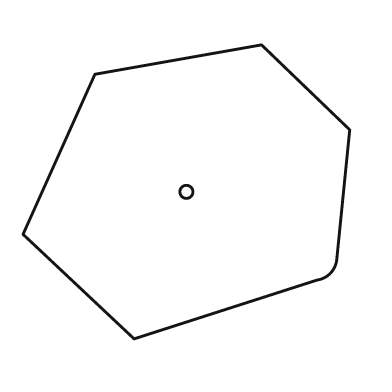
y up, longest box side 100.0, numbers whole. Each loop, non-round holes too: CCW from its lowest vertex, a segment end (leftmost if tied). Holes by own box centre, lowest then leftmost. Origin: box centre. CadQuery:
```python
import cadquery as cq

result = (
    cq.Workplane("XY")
    .moveTo(-16.0, -45.0)
    .lineTo(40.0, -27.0)
    .threePointArc((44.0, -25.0), (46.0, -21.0))
    .lineTo(50.0, 19.0)
    .lineTo(23.0, 45.0)
    .lineTo(-28.0, 36.0)
    .lineTo(-50.0, -13.0)
    .close()
    .moveTo(0.0, 0.0)
    .circle(2.0)
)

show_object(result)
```